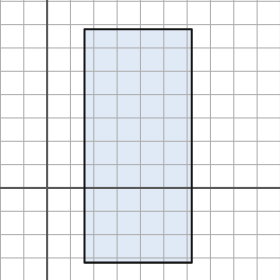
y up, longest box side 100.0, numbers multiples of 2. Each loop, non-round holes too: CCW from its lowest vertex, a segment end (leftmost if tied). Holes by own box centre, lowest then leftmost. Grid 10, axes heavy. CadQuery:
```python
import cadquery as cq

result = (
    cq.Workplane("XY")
    .moveTo(16.0, -32.0)
    .lineTo(62.0, -32.0)
    .lineTo(62.0, 68.0)
    .lineTo(16.0, 68.0)
    .close()
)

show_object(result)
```